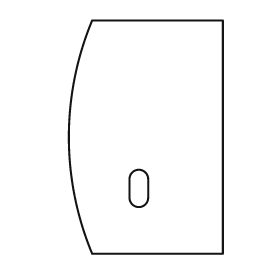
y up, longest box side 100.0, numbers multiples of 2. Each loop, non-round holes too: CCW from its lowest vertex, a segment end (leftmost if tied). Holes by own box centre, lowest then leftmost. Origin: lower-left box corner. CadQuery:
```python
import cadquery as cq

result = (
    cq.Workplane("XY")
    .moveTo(10.0, 0.0)
    .lineTo(66.0, 0.0)
    .lineTo(66.0, 100.0)
    .lineTo(10.0, 100.0)
    .threePointArc((0.0, 50.0), (10.0, 0.0))
    .close()
    .moveTo(26.0, 24.0)
    .threePointArc((30.0, 20.0), (34.0, 24.0))
    .lineTo(34.0, 32.0)
    .threePointArc((30.0, 36.0), (26.0, 32.0))
    .close()
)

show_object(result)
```